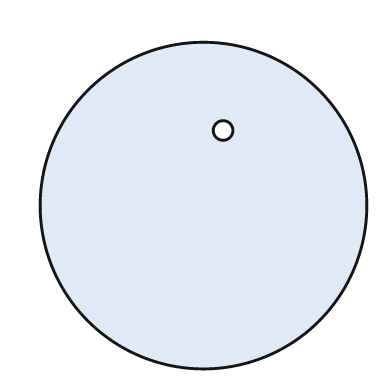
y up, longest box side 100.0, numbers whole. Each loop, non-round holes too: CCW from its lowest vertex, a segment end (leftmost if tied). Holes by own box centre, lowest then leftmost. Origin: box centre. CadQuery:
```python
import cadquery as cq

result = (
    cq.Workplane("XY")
    .moveTo(0.0, 0.0)
    .circle(50.0)
    .moveTo(6.0, 23.0)
    .circle(3.0)
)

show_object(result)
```